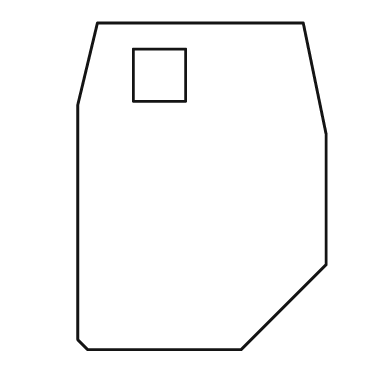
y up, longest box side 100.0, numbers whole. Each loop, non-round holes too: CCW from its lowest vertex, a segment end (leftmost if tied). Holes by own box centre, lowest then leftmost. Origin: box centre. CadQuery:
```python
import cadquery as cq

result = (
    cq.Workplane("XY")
    .moveTo(-35.0, -50.0)
    .lineTo(12.0, -50.0)
    .lineTo(38.0, -24.0)
    .lineTo(38.0, 16.0)
    .lineTo(31.0, 50.0)
    .lineTo(-32.0, 50.0)
    .lineTo(-38.0, 25.0)
    .lineTo(-38.0, -47.0)
    .close()
    .moveTo(-21.0, 26.0)
    .lineTo(-5.0, 26.0)
    .lineTo(-5.0, 42.0)
    .lineTo(-21.0, 42.0)
    .close()
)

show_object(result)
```